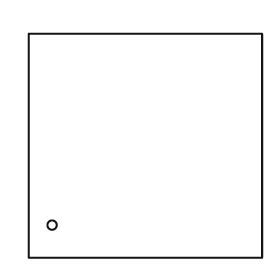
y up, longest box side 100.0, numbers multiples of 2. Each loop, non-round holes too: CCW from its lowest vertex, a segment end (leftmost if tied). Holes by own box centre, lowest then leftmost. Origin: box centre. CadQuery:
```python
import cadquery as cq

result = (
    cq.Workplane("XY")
    .moveTo(-50.0, -48.0)
    .lineTo(50.0, -48.0)
    .lineTo(50.0, 48.0)
    .lineTo(-50.0, 48.0)
    .close()
    .moveTo(-40.0, -34.0)
    .circle(2.0)
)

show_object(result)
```